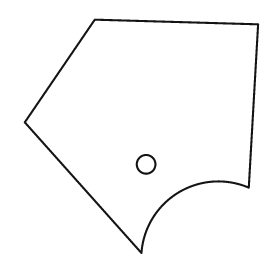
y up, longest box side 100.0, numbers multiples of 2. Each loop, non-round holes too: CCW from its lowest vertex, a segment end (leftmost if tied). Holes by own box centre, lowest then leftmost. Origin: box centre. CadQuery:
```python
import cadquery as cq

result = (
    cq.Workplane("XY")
    .moveTo(0.0, -50.0)
    .threePointArc((16.0, -24.0), (46.0, -22.0))
    .lineTo(50.0, 48.0)
    .lineTo(-20.0, 50.0)
    .lineTo(-50.0, 6.0)
    .close()
    .moveTo(2.0, -12.0)
    .circle(4.0)
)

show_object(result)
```